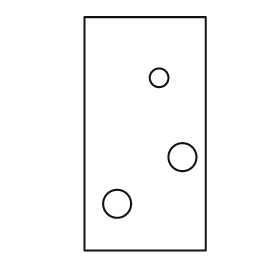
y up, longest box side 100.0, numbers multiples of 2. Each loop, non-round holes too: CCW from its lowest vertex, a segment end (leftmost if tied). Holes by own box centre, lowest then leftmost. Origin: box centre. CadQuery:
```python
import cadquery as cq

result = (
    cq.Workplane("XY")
    .moveTo(-26.0, -50.0)
    .lineTo(26.0, -50.0)
    .lineTo(26.0, 50.0)
    .lineTo(-26.0, 50.0)
    .close()
    .moveTo(-12.0, -30.0)
    .circle(6.0)
    .moveTo(16.0, -10.0)
    .circle(6.0)
    .moveTo(6.0, 24.0)
    .circle(4.0)
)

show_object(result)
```